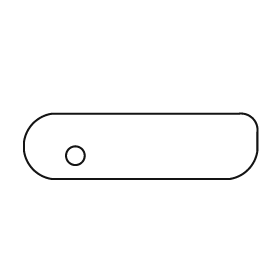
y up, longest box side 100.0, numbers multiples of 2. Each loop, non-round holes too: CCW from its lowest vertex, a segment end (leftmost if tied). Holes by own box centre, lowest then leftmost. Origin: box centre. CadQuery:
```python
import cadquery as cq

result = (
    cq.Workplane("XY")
    .moveTo(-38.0, -14.0)
    .lineTo(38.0, -14.0)
    .threePointArc((46.0, -10.0), (50.0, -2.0))
    .lineTo(50.0, 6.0)
    .threePointArc((48.0, 12.0), (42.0, 14.0))
    .lineTo(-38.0, 14.0)
    .threePointArc((-46.0, 10.0), (-50.0, 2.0))
    .lineTo(-50.0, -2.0)
    .threePointArc((-46.0, -10.0), (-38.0, -14.0))
    .close()
    .moveTo(-28.0, -4.0)
    .circle(4.0)
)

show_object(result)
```